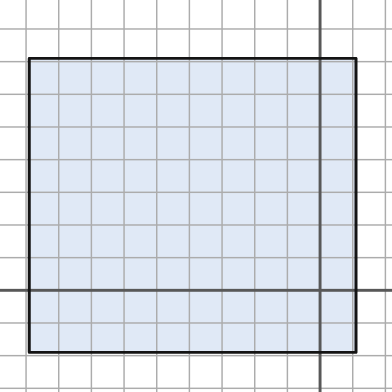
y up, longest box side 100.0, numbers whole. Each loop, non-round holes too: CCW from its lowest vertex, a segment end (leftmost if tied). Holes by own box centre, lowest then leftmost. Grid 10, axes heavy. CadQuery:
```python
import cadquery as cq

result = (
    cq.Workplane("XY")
    .moveTo(-89.0, -19.0)
    .lineTo(11.0, -19.0)
    .lineTo(11.0, 71.0)
    .lineTo(-89.0, 71.0)
    .close()
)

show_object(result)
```